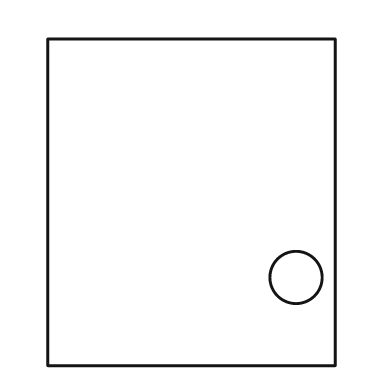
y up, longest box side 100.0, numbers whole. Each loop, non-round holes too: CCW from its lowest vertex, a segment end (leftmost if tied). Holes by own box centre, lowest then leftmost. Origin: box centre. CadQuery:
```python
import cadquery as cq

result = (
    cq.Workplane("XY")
    .moveTo(-44.0, -50.0)
    .lineTo(44.0, -50.0)
    .lineTo(44.0, 50.0)
    .lineTo(-44.0, 50.0)
    .close()
    .moveTo(32.0, -23.0)
    .circle(8.0)
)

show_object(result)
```